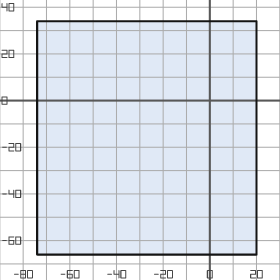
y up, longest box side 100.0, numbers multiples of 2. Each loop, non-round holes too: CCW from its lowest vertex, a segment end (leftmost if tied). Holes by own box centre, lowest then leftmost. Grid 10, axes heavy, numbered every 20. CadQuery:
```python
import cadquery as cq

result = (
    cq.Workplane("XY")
    .moveTo(-74.0, -66.0)
    .lineTo(20.0, -66.0)
    .lineTo(20.0, 34.0)
    .lineTo(-74.0, 34.0)
    .close()
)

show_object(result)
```